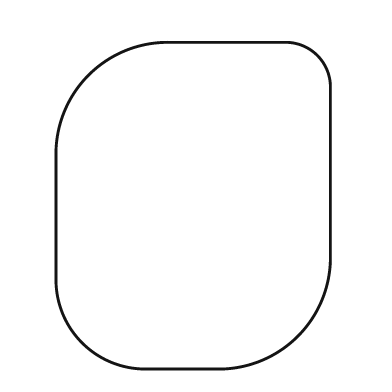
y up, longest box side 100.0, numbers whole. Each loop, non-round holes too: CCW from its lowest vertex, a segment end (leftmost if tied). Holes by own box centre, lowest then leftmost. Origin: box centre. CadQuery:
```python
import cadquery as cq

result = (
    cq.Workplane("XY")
    .moveTo(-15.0, -50.0)
    .lineTo(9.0, -50.0)
    .threePointArc((32.0, -40.0), (42.0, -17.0))
    .lineTo(42.0, 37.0)
    .threePointArc((38.0, 46.0), (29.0, 50.0))
    .lineTo(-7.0, 50.0)
    .threePointArc((-32.0, 40.0), (-42.0, 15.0))
    .lineTo(-42.0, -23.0)
    .threePointArc((-34.0, -42.0), (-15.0, -50.0))
    .close()
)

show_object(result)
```